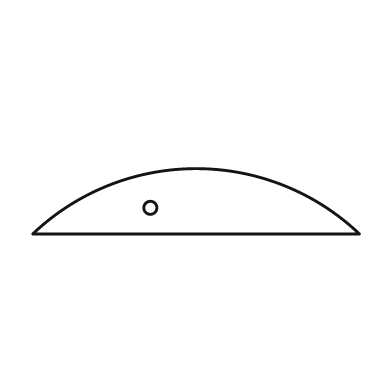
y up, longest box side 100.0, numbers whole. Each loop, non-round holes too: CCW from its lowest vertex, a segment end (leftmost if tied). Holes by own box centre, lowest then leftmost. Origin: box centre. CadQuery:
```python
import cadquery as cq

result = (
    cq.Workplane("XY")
    .moveTo(-50.0, -10.0)
    .lineTo(50.0, -10.0)
    .threePointArc((0.0, 10.0), (-50.0, -10.0))
    .close()
    .moveTo(-14.0, -2.0)
    .circle(2.0)
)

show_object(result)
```